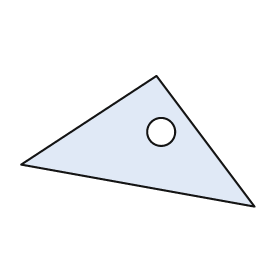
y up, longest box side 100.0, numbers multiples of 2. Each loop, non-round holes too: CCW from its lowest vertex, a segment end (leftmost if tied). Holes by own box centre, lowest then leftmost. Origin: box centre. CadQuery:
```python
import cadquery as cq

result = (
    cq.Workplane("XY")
    .moveTo(50.0, -28.0)
    .lineTo(8.0, 28.0)
    .lineTo(-50.0, -10.0)
    .close()
    .moveTo(10.0, 4.0)
    .circle(6.0)
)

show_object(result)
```